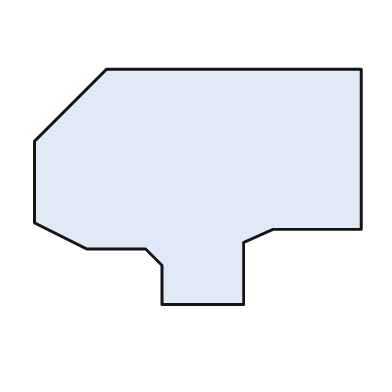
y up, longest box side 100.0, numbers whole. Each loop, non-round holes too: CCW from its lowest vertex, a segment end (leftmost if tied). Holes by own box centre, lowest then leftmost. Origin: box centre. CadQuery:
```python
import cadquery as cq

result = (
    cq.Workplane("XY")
    .moveTo(-11.0, -36.0)
    .lineTo(14.0, -36.0)
    .lineTo(14.0, -17.0)
    .lineTo(23.0, -13.0)
    .lineTo(50.0, -13.0)
    .lineTo(50.0, 36.0)
    .lineTo(-28.0, 36.0)
    .lineTo(-50.0, 14.0)
    .lineTo(-50.0, -11.0)
    .lineTo(-34.0, -19.0)
    .lineTo(-16.0, -19.0)
    .lineTo(-11.0, -24.0)
    .close()
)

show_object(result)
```